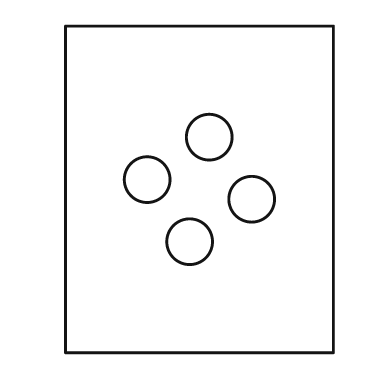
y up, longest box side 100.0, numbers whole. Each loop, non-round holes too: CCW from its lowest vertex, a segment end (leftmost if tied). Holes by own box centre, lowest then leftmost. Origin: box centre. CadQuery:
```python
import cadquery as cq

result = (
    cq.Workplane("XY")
    .moveTo(-41.0, -50.0)
    .lineTo(41.0, -50.0)
    .lineTo(41.0, 50.0)
    .lineTo(-41.0, 50.0)
    .close()
    .moveTo(-3.0, -16.0)
    .circle(7.0)
    .moveTo(16.0, -3.0)
    .circle(7.0)
    .moveTo(-16.0, 3.0)
    .circle(7.0)
    .moveTo(3.0, 16.0)
    .circle(7.0)
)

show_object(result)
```